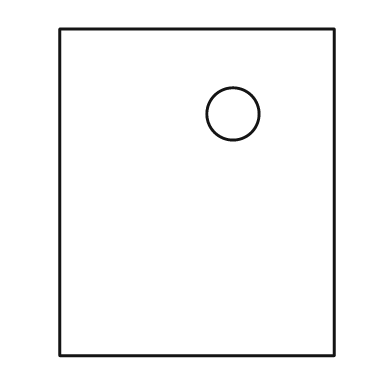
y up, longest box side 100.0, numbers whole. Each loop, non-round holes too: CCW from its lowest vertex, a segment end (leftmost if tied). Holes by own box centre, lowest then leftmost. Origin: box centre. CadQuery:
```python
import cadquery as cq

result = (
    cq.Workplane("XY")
    .moveTo(-42.0, -50.0)
    .lineTo(42.0, -50.0)
    .lineTo(42.0, 50.0)
    .lineTo(-42.0, 50.0)
    .close()
    .moveTo(11.0, 24.0)
    .circle(8.0)
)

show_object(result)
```